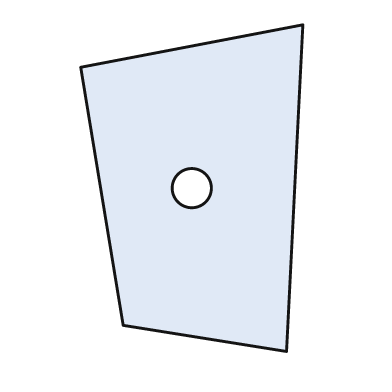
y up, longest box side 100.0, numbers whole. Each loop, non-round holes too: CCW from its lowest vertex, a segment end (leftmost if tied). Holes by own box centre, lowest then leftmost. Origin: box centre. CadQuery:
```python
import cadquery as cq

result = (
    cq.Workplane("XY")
    .moveTo(29.0, -50.0)
    .lineTo(34.0, 50.0)
    .lineTo(-34.0, 37.0)
    .lineTo(-21.0, -42.0)
    .close()
    .moveTo(0.0, 0.0)
    .circle(6.0)
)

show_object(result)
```